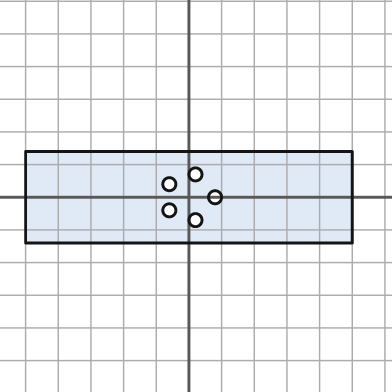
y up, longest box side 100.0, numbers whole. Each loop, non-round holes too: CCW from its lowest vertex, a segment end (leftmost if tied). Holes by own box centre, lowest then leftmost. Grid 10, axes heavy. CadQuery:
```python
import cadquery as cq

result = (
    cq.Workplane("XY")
    .moveTo(-50.0, -14.0)
    .lineTo(50.0, -14.0)
    .lineTo(50.0, 14.0)
    .lineTo(-50.0, 14.0)
    .close()
    .moveTo(2.0, -7.0)
    .circle(2.0)
    .moveTo(-6.0, -4.0)
    .circle(2.0)
    .moveTo(8.0, 0.0)
    .circle(2.0)
    .moveTo(-6.0, 4.0)
    .circle(2.0)
    .moveTo(2.0, 7.0)
    .circle(2.0)
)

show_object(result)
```